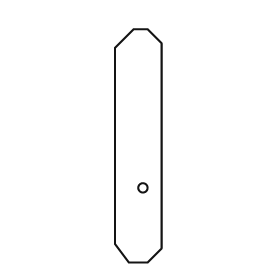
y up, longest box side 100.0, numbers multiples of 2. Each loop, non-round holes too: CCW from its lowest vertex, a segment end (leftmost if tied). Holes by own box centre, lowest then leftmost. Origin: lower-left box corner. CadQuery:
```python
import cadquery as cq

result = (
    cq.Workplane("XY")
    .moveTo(6.0, 0.0)
    .lineTo(14.0, 0.0)
    .lineTo(20.0, 6.0)
    .lineTo(20.0, 94.0)
    .lineTo(14.0, 100.0)
    .lineTo(8.0, 100.0)
    .lineTo(0.0, 92.0)
    .lineTo(0.0, 8.0)
    .close()
    .moveTo(12.0, 32.0)
    .circle(2.0)
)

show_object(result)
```